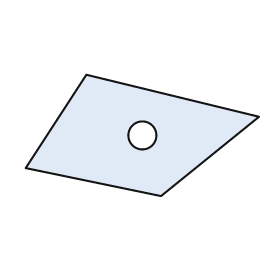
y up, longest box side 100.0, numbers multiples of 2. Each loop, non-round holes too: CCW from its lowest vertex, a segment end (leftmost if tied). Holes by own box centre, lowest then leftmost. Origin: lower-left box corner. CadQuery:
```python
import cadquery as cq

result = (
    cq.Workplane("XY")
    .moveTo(58.0, 0.0)
    .lineTo(100.0, 34.0)
    .lineTo(26.0, 52.0)
    .lineTo(0.0, 12.0)
    .close()
    .moveTo(50.0, 26.0)
    .circle(6.0)
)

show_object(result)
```